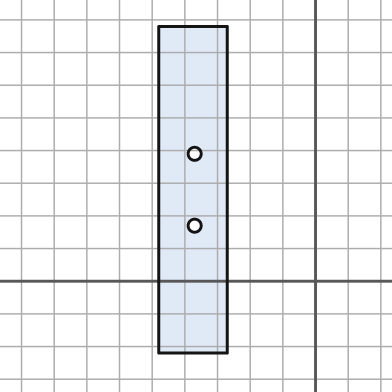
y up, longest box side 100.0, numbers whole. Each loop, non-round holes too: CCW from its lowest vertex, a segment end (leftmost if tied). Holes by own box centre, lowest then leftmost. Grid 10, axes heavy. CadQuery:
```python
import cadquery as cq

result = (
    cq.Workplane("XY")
    .moveTo(-48.0, -22.0)
    .lineTo(-27.0, -22.0)
    .lineTo(-27.0, 78.0)
    .lineTo(-48.0, 78.0)
    .close()
    .moveTo(-37.0, 17.0)
    .circle(2.0)
    .moveTo(-37.0, 39.0)
    .circle(2.0)
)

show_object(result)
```